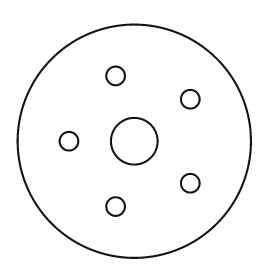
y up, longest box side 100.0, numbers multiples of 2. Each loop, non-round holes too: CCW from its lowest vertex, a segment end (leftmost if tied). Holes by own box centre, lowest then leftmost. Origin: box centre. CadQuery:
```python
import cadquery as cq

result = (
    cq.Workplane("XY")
    .moveTo(0.0, 0.0)
    .circle(50.0)
    .moveTo(-8.0, -28.0)
    .circle(4.0)
    .moveTo(24.0, -18.0)
    .circle(4.0)
    .moveTo(-28.0, 0.0)
    .circle(4.0)
    .moveTo(0.0, 0.0)
    .circle(10.0)
    .moveTo(24.0, 18.0)
    .circle(4.0)
    .moveTo(-8.0, 28.0)
    .circle(4.0)
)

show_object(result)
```